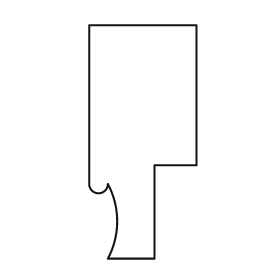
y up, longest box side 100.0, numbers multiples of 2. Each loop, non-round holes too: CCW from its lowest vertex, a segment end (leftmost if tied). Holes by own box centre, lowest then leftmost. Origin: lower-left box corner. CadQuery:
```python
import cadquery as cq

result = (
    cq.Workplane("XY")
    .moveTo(8.0, 0.0)
    .lineTo(28.0, 0.0)
    .lineTo(28.0, 40.0)
    .lineTo(46.0, 40.0)
    .lineTo(46.0, 100.0)
    .lineTo(0.0, 100.0)
    .lineTo(0.0, 32.0)
    .threePointArc((4.0, 28.0), (8.0, 32.0))
    .threePointArc((12.0, 16.0), (8.0, 0.0))
    .close()
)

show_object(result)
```